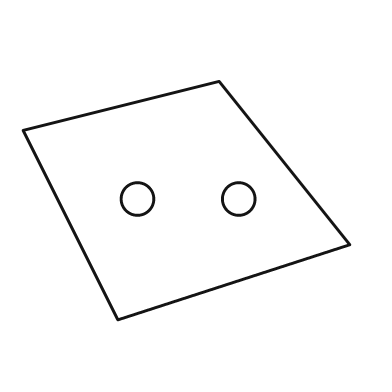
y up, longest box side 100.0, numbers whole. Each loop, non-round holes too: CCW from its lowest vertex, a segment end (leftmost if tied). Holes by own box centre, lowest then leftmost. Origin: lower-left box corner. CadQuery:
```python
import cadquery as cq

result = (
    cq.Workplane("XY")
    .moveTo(29.0, 0.0)
    .lineTo(100.0, 23.0)
    .lineTo(60.0, 73.0)
    .lineTo(0.0, 58.0)
    .close()
    .moveTo(35.0, 37.0)
    .circle(5.0)
    .moveTo(66.0, 37.0)
    .circle(5.0)
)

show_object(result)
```